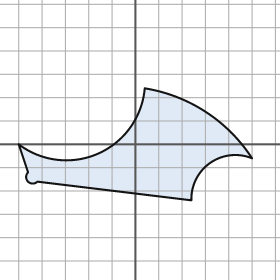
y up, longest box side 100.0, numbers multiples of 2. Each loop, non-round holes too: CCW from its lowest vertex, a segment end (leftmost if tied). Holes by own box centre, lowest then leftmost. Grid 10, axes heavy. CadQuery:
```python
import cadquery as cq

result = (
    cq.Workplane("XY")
    .moveTo(24.0, -24.0)
    .threePointArc((32.0, -8.0), (50.0, -6.0))
    .threePointArc((30.0, 14.0), (4.0, 24.0))
    .threePointArc((-16.0, -4.0), (-50.0, 0.0))
    .lineTo(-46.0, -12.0)
    .threePointArc((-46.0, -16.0), (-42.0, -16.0))
    .close()
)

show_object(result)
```